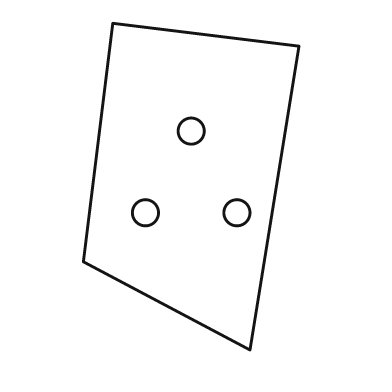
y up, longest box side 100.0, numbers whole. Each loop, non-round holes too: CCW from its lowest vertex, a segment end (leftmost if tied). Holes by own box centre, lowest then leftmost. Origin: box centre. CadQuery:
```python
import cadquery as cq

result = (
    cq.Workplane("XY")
    .moveTo(18.0, -50.0)
    .lineTo(33.0, 43.0)
    .lineTo(-24.0, 50.0)
    .lineTo(-33.0, -23.0)
    .close()
    .moveTo(-14.0, -8.0)
    .circle(4.0)
    .moveTo(14.0, -8.0)
    .circle(4.0)
    .moveTo(0.0, 17.0)
    .circle(4.0)
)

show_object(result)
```